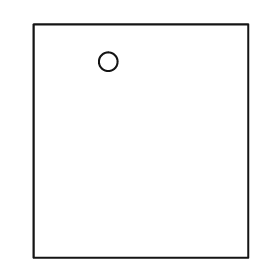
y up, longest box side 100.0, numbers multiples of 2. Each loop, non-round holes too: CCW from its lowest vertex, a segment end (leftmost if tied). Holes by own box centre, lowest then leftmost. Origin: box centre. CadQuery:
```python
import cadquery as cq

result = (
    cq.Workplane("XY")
    .moveTo(-46.0, -50.0)
    .lineTo(46.0, -50.0)
    .lineTo(46.0, 50.0)
    .lineTo(-46.0, 50.0)
    .close()
    .moveTo(-14.0, 34.0)
    .circle(4.0)
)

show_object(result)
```